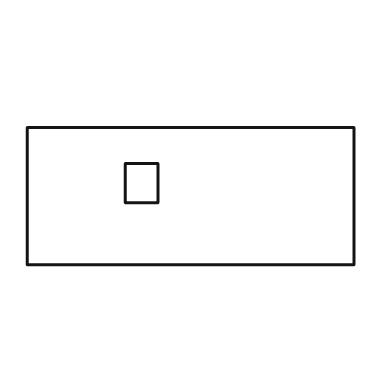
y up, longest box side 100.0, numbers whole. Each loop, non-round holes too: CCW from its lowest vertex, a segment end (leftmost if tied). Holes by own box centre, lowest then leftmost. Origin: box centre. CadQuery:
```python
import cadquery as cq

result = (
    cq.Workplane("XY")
    .moveTo(-50.0, -21.0)
    .lineTo(50.0, -21.0)
    .lineTo(50.0, 21.0)
    .lineTo(-50.0, 21.0)
    .close()
    .moveTo(-20.0, -2.0)
    .lineTo(-10.0, -2.0)
    .lineTo(-10.0, 10.0)
    .lineTo(-20.0, 10.0)
    .close()
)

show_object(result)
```